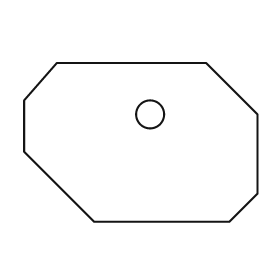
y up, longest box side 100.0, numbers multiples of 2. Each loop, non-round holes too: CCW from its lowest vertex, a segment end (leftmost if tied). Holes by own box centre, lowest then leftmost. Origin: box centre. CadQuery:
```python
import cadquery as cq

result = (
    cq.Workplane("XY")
    .moveTo(-20.0, -34.0)
    .lineTo(38.0, -34.0)
    .lineTo(50.0, -22.0)
    .lineTo(50.0, 12.0)
    .lineTo(28.0, 34.0)
    .lineTo(-36.0, 34.0)
    .lineTo(-50.0, 18.0)
    .lineTo(-50.0, -4.0)
    .close()
    .moveTo(4.0, 12.0)
    .circle(6.0)
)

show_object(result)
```